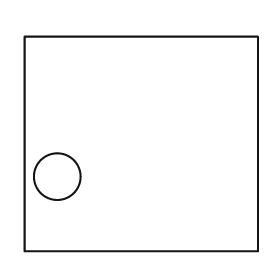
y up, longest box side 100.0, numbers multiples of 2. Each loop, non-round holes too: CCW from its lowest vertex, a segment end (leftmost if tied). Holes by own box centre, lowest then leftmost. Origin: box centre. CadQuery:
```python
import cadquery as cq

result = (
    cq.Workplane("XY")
    .moveTo(-50.0, -46.0)
    .lineTo(50.0, -46.0)
    .lineTo(50.0, 46.0)
    .lineTo(-50.0, 46.0)
    .close()
    .moveTo(-36.0, -14.0)
    .circle(10.0)
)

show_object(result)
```